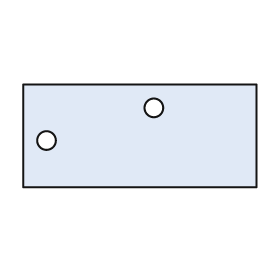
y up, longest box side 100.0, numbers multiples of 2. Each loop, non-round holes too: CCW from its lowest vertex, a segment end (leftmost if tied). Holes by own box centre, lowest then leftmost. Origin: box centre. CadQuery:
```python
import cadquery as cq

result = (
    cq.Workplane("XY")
    .moveTo(-50.0, -22.0)
    .lineTo(50.0, -22.0)
    .lineTo(50.0, 22.0)
    .lineTo(-50.0, 22.0)
    .close()
    .moveTo(-40.0, -2.0)
    .circle(4.0)
    .moveTo(6.0, 12.0)
    .circle(4.0)
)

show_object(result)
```